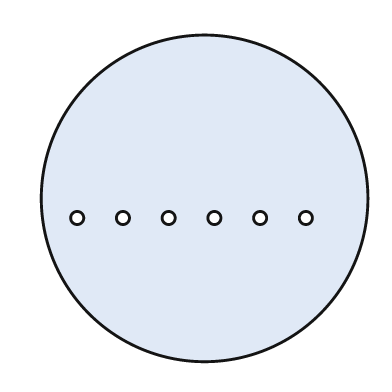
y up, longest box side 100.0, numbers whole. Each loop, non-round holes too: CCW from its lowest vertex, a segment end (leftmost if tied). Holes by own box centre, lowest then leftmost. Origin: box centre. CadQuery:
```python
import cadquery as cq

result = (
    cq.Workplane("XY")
    .moveTo(0.0, 0.0)
    .circle(50.0)
    .moveTo(-39.0, -6.0)
    .circle(2.0)
    .moveTo(-25.0, -6.0)
    .circle(2.0)
    .moveTo(-11.0, -6.0)
    .circle(2.0)
    .moveTo(3.0, -6.0)
    .circle(2.0)
    .moveTo(17.0, -6.0)
    .circle(2.0)
    .moveTo(31.0, -6.0)
    .circle(2.0)
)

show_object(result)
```